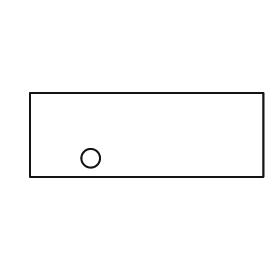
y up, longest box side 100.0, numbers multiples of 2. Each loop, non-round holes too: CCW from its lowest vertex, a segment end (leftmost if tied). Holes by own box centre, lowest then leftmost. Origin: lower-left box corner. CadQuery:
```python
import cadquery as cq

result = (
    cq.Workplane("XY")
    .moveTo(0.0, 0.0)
    .lineTo(100.0, 0.0)
    .lineTo(100.0, 36.0)
    .lineTo(0.0, 36.0)
    .close()
    .moveTo(26.0, 8.0)
    .circle(4.0)
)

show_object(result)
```